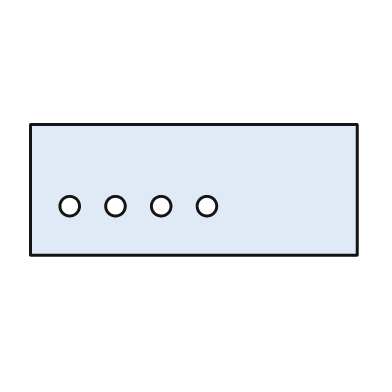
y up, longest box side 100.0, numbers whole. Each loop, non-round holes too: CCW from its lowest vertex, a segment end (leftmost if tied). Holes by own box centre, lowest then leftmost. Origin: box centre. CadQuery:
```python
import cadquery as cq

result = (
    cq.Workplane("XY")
    .moveTo(-50.0, -20.0)
    .lineTo(50.0, -20.0)
    .lineTo(50.0, 20.0)
    .lineTo(-50.0, 20.0)
    .close()
    .moveTo(-38.0, -5.0)
    .circle(3.0)
    .moveTo(-24.0, -5.0)
    .circle(3.0)
    .moveTo(-10.0, -5.0)
    .circle(3.0)
    .moveTo(4.0, -5.0)
    .circle(3.0)
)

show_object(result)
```